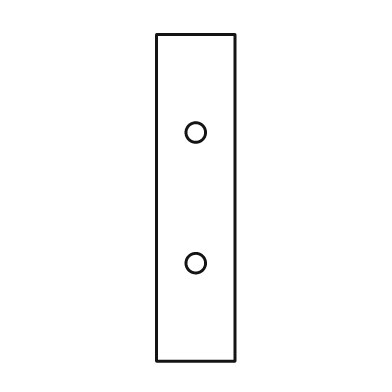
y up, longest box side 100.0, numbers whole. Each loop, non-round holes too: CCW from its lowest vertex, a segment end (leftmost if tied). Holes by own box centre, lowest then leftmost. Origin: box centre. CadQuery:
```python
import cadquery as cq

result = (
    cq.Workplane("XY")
    .moveTo(-12.0, -50.0)
    .lineTo(12.0, -50.0)
    .lineTo(12.0, 50.0)
    .lineTo(-12.0, 50.0)
    .close()
    .moveTo(0.0, -20.0)
    .circle(3.0)
    .moveTo(0.0, 20.0)
    .circle(3.0)
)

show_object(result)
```